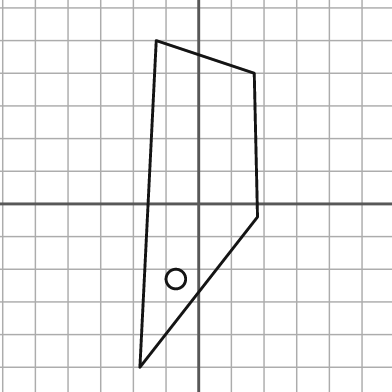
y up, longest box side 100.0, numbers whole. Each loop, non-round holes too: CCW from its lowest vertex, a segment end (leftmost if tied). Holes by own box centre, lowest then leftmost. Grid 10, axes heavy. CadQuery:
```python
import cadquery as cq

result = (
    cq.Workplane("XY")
    .moveTo(-18.0, -50.0)
    .lineTo(18.0, -4.0)
    .lineTo(17.0, 40.0)
    .lineTo(-13.0, 50.0)
    .close()
    .moveTo(-7.0, -23.0)
    .circle(3.0)
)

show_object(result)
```